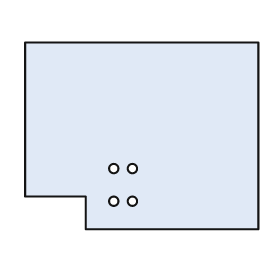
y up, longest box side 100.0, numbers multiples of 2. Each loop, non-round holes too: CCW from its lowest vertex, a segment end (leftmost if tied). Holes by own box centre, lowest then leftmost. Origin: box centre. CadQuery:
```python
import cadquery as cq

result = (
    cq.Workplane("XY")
    .moveTo(-24.0, -40.0)
    .lineTo(50.0, -40.0)
    .lineTo(50.0, 40.0)
    .lineTo(-50.0, 40.0)
    .lineTo(-50.0, -26.0)
    .lineTo(-24.0, -26.0)
    .close()
    .moveTo(-12.0, -28.0)
    .circle(2.0)
    .moveTo(-4.0, -28.0)
    .circle(2.0)
    .moveTo(-12.0, -14.0)
    .circle(2.0)
    .moveTo(-4.0, -14.0)
    .circle(2.0)
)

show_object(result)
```